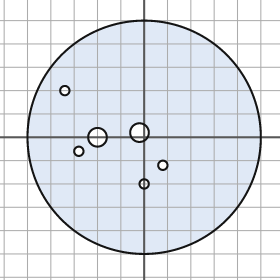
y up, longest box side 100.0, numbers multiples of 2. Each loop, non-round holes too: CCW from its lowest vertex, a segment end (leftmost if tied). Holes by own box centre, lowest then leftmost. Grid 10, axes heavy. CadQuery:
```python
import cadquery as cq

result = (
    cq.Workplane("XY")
    .moveTo(0.0, 0.0)
    .circle(50.0)
    .moveTo(0.0, -20.0)
    .circle(2.0)
    .moveTo(8.0, -12.0)
    .circle(2.0)
    .moveTo(-28.0, -6.0)
    .circle(2.0)
    .moveTo(-20.0, 0.0)
    .circle(4.0)
    .moveTo(-2.0, 2.0)
    .circle(4.0)
    .moveTo(-34.0, 20.0)
    .circle(2.0)
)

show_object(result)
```